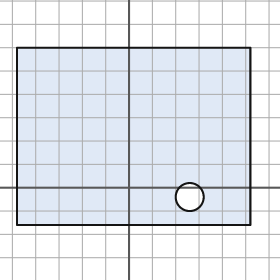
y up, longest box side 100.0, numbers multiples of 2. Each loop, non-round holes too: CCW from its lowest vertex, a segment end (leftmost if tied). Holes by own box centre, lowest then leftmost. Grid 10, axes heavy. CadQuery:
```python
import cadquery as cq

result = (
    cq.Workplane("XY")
    .moveTo(-48.0, -16.0)
    .lineTo(52.0, -16.0)
    .lineTo(52.0, 60.0)
    .lineTo(-48.0, 60.0)
    .close()
    .moveTo(26.0, -4.0)
    .circle(6.0)
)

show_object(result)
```